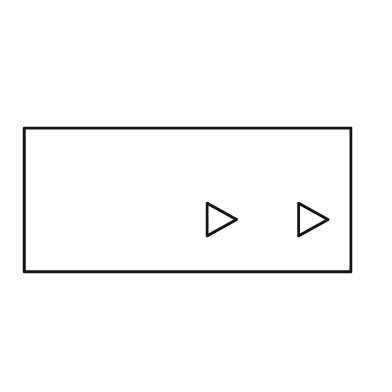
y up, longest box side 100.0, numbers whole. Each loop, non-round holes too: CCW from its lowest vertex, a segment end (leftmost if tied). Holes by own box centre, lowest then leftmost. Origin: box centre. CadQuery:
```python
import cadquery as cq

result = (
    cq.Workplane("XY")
    .moveTo(-50.0, -22.0)
    .lineTo(50.0, -22.0)
    .lineTo(50.0, 22.0)
    .lineTo(-50.0, 22.0)
    .close()
    .moveTo(6.0, -11.0)
    .lineTo(15.0, -6.0)
    .lineTo(6.0, -1.0)
    .close()
    .moveTo(34.0, -11.0)
    .lineTo(43.0, -6.0)
    .lineTo(34.0, -1.0)
    .close()
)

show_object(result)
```